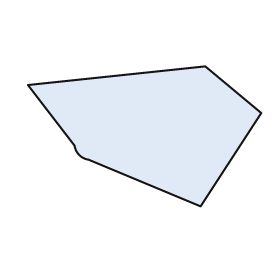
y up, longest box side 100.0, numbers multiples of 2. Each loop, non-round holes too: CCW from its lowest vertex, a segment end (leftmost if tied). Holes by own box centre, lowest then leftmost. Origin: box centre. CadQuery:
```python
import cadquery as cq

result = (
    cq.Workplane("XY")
    .moveTo(24.0, -30.0)
    .lineTo(50.0, 10.0)
    .lineTo(26.0, 30.0)
    .lineTo(-50.0, 22.0)
    .lineTo(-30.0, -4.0)
    .threePointArc((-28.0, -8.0), (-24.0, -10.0))
    .close()
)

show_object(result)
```